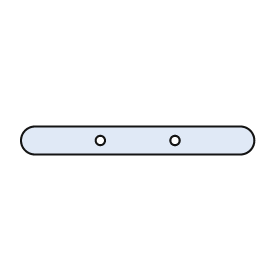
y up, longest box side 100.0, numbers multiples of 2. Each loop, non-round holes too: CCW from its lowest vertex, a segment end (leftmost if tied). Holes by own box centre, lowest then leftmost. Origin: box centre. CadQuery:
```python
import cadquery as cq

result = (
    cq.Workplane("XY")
    .moveTo(-44.0, -6.0)
    .lineTo(44.0, -6.0)
    .threePointArc((50.0, 0.0), (44.0, 6.0))
    .lineTo(-44.0, 6.0)
    .threePointArc((-50.0, 0.0), (-44.0, -6.0))
    .close()
    .moveTo(-16.0, 0.0)
    .circle(2.0)
    .moveTo(16.0, 0.0)
    .circle(2.0)
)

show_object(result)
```